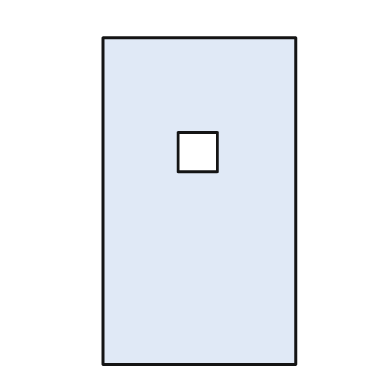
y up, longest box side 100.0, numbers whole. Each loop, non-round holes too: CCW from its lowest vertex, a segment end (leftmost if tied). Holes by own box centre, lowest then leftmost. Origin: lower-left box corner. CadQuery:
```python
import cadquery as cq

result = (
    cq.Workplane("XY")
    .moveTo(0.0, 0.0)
    .lineTo(59.0, 0.0)
    .lineTo(59.0, 100.0)
    .lineTo(0.0, 100.0)
    .close()
    .moveTo(23.0, 59.0)
    .lineTo(35.0, 59.0)
    .lineTo(35.0, 71.0)
    .lineTo(23.0, 71.0)
    .close()
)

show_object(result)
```